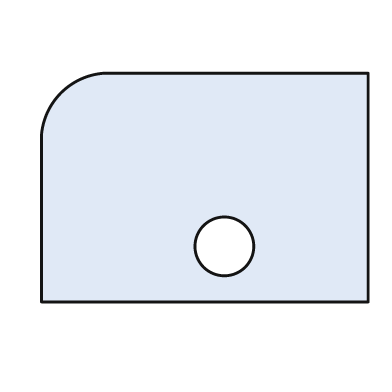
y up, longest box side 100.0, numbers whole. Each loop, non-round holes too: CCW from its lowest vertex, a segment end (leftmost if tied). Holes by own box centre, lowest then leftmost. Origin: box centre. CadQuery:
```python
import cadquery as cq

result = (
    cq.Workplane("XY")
    .moveTo(-50.0, -35.0)
    .lineTo(50.0, -35.0)
    .lineTo(50.0, 35.0)
    .lineTo(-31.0, 35.0)
    .threePointArc((-44.0, 29.0), (-50.0, 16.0))
    .close()
    .moveTo(6.0, -18.0)
    .circle(9.0)
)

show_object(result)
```